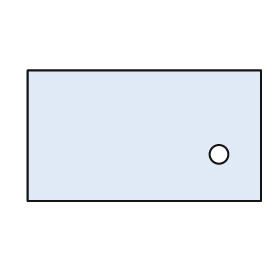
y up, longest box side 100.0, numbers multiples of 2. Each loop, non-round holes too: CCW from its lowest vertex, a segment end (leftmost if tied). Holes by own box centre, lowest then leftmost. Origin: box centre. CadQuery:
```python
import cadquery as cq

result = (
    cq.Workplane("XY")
    .moveTo(-50.0, -28.0)
    .lineTo(50.0, -28.0)
    .lineTo(50.0, 28.0)
    .lineTo(-50.0, 28.0)
    .close()
    .moveTo(32.0, -8.0)
    .circle(4.0)
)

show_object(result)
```